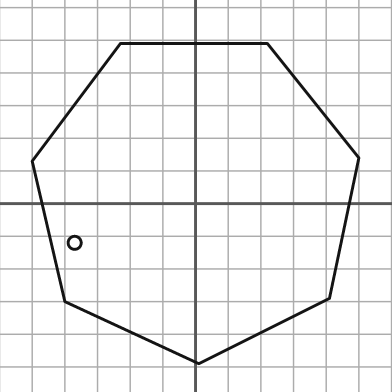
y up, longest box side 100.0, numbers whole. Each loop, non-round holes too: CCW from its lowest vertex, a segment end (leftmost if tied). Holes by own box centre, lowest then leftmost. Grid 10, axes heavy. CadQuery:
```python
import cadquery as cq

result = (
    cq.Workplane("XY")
    .moveTo(1.0, -49.0)
    .lineTo(41.0, -29.0)
    .lineTo(50.0, 14.0)
    .lineTo(22.0, 49.0)
    .lineTo(-23.0, 49.0)
    .lineTo(-50.0, 13.0)
    .lineTo(-40.0, -30.0)
    .close()
    .moveTo(-37.0, -12.0)
    .circle(2.0)
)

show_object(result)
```